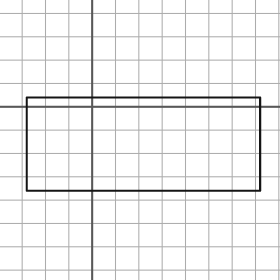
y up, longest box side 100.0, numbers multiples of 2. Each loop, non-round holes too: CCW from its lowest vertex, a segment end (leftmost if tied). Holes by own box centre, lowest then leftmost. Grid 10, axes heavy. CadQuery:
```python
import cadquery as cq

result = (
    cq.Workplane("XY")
    .moveTo(-28.0, -36.0)
    .lineTo(72.0, -36.0)
    .lineTo(72.0, 4.0)
    .lineTo(-28.0, 4.0)
    .close()
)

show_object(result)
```